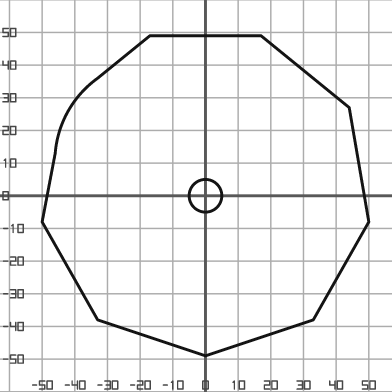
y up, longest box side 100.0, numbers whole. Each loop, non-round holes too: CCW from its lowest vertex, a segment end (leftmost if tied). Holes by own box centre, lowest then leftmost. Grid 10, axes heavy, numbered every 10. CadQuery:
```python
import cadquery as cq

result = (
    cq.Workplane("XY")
    .moveTo(0.0, -49.0)
    .lineTo(33.0, -38.0)
    .lineTo(50.0, -8.0)
    .lineTo(44.0, 27.0)
    .lineTo(17.0, 49.0)
    .lineTo(-17.0, 49.0)
    .lineTo(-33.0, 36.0)
    .threePointArc((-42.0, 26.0), (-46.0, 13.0))
    .lineTo(-50.0, -8.0)
    .lineTo(-33.0, -38.0)
    .close()
    .moveTo(0.0, 0.0)
    .circle(5.0)
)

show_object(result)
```